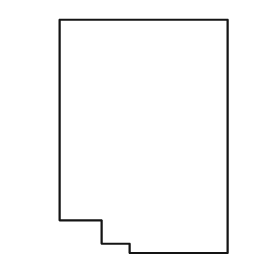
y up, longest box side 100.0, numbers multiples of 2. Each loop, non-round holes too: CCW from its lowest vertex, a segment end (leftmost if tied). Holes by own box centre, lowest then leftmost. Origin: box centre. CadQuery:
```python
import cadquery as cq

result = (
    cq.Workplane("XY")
    .moveTo(-6.0, -50.0)
    .lineTo(36.0, -50.0)
    .lineTo(36.0, 50.0)
    .lineTo(-36.0, 50.0)
    .lineTo(-36.0, -36.0)
    .lineTo(-18.0, -36.0)
    .lineTo(-18.0, -46.0)
    .lineTo(-6.0, -46.0)
    .close()
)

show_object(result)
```